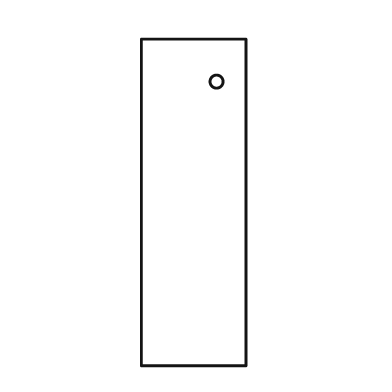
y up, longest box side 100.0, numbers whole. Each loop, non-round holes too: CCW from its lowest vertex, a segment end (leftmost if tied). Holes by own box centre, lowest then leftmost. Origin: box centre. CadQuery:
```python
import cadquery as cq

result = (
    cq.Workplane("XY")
    .moveTo(-16.0, -50.0)
    .lineTo(16.0, -50.0)
    .lineTo(16.0, 50.0)
    .lineTo(-16.0, 50.0)
    .close()
    .moveTo(7.0, 37.0)
    .circle(2.0)
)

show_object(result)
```